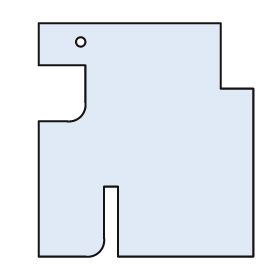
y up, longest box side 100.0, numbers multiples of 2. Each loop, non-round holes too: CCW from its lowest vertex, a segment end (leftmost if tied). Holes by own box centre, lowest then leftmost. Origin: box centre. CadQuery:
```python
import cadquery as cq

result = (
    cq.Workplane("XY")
    .moveTo(-46.0, -50.0)
    .lineTo(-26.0, -50.0)
    .threePointArc((-20.0, -48.0), (-18.0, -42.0))
    .lineTo(-18.0, -20.0)
    .lineTo(-12.0, -20.0)
    .lineTo(-12.0, -50.0)
    .lineTo(46.0, -50.0)
    .lineTo(46.0, 22.0)
    .lineTo(32.0, 22.0)
    .lineTo(32.0, 50.0)
    .lineTo(-46.0, 50.0)
    .lineTo(-46.0, 32.0)
    .lineTo(-26.0, 32.0)
    .lineTo(-26.0, 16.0)
    .threePointArc((-28.0, 10.0), (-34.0, 8.0))
    .lineTo(-46.0, 8.0)
    .close()
    .moveTo(-28.0, 42.0)
    .circle(2.0)
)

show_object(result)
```